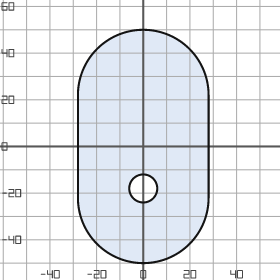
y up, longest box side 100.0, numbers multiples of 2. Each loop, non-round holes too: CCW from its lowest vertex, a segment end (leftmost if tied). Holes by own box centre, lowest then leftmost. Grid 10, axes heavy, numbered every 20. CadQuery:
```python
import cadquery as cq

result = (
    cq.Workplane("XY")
    .moveTo(-28.0, -22.0)
    .threePointArc((0.0, -50.0), (28.0, -22.0))
    .lineTo(28.0, 22.0)
    .threePointArc((0.0, 50.0), (-28.0, 22.0))
    .close()
    .moveTo(0.0, -18.0)
    .circle(6.0)
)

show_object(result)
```